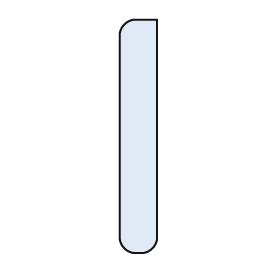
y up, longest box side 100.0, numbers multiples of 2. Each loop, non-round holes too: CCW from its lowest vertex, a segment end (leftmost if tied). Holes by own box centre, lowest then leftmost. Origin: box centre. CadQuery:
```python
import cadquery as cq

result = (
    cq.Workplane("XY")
    .moveTo(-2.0, -50.0)
    .lineTo(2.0, -50.0)
    .threePointArc((6.0, -48.0), (8.0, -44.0))
    .lineTo(8.0, 50.0)
    .lineTo(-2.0, 50.0)
    .threePointArc((-6.0, 48.0), (-8.0, 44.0))
    .lineTo(-8.0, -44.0)
    .threePointArc((-6.0, -48.0), (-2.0, -50.0))
    .close()
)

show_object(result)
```